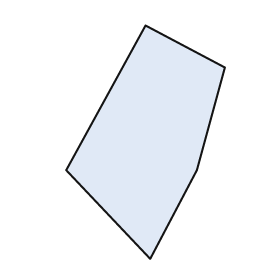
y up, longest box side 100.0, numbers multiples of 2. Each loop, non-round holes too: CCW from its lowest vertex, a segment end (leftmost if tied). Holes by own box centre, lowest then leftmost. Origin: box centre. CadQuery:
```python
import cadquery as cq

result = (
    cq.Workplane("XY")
    .moveTo(2.0, -50.0)
    .lineTo(22.0, -12.0)
    .lineTo(34.0, 32.0)
    .lineTo(0.0, 50.0)
    .lineTo(-34.0, -12.0)
    .close()
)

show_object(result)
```